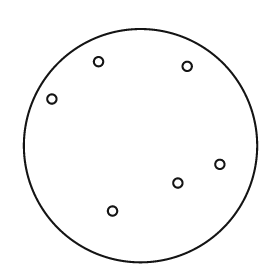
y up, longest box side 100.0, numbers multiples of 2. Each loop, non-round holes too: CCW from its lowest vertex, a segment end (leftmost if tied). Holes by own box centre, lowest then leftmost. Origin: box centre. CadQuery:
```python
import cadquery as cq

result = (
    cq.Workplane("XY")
    .moveTo(0.0, 0.0)
    .circle(50.0)
    .moveTo(-12.0, -28.0)
    .circle(2.0)
    .moveTo(16.0, -16.0)
    .circle(2.0)
    .moveTo(34.0, -8.0)
    .circle(2.0)
    .moveTo(-38.0, 20.0)
    .circle(2.0)
    .moveTo(20.0, 34.0)
    .circle(2.0)
    .moveTo(-18.0, 36.0)
    .circle(2.0)
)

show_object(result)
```